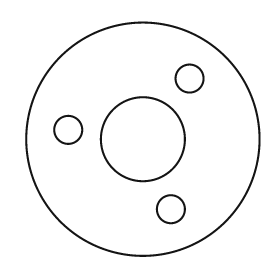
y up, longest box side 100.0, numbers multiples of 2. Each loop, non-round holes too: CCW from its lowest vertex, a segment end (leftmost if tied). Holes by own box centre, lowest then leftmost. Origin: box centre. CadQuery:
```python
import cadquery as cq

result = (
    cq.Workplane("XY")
    .moveTo(0.0, 0.0)
    .circle(50.0)
    .moveTo(12.0, -30.0)
    .circle(6.0)
    .moveTo(0.0, 0.0)
    .circle(18.0)
    .moveTo(-32.0, 4.0)
    .circle(6.0)
    .moveTo(20.0, 26.0)
    .circle(6.0)
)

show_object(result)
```